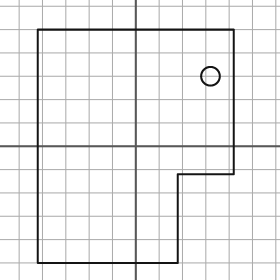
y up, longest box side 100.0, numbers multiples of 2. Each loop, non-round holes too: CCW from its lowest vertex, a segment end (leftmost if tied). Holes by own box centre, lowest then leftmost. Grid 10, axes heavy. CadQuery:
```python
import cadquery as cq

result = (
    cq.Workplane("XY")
    .moveTo(-42.0, -50.0)
    .lineTo(18.0, -50.0)
    .lineTo(18.0, -12.0)
    .lineTo(42.0, -12.0)
    .lineTo(42.0, 50.0)
    .lineTo(-42.0, 50.0)
    .close()
    .moveTo(32.0, 30.0)
    .circle(4.0)
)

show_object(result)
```